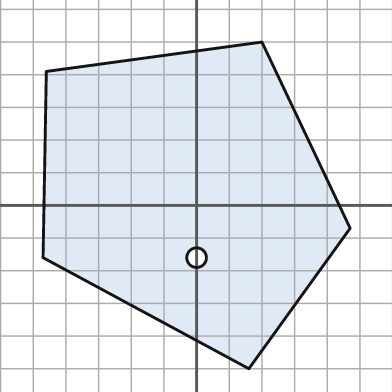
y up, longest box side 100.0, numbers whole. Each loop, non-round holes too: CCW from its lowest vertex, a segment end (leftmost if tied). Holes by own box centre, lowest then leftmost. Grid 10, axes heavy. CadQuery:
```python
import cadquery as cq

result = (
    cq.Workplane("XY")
    .moveTo(16.0, -50.0)
    .lineTo(47.0, -7.0)
    .lineTo(20.0, 50.0)
    .lineTo(-46.0, 41.0)
    .lineTo(-47.0, -16.0)
    .close()
    .moveTo(0.0, -16.0)
    .circle(3.0)
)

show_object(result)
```